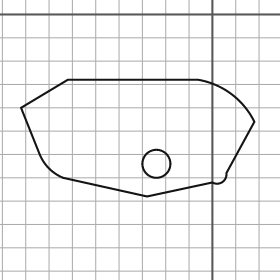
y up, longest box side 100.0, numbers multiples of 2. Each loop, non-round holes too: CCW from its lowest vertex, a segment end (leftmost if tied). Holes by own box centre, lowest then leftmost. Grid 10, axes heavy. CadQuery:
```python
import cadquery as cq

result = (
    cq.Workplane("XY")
    .moveTo(-28.0, -78.0)
    .lineTo(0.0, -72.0)
    .threePointArc((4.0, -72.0), (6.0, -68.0))
    .lineTo(18.0, -46.0)
    .threePointArc((8.0, -34.0), (-6.0, -28.0))
    .lineTo(-62.0, -28.0)
    .lineTo(-82.0, -40.0)
    .lineTo(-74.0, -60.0)
    .threePointArc((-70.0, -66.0), (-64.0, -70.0))
    .close()
    .moveTo(-24.0, -64.0)
    .circle(6.0)
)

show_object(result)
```